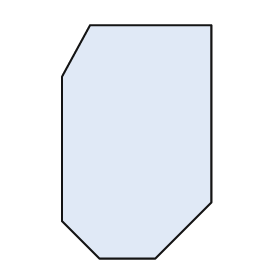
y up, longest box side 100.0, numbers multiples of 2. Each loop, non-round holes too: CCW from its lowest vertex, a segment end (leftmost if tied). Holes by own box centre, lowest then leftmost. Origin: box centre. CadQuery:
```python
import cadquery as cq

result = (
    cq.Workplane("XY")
    .moveTo(-16.0, -50.0)
    .lineTo(8.0, -50.0)
    .lineTo(32.0, -26.0)
    .lineTo(32.0, 50.0)
    .lineTo(-20.0, 50.0)
    .lineTo(-32.0, 28.0)
    .lineTo(-32.0, -34.0)
    .close()
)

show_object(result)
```